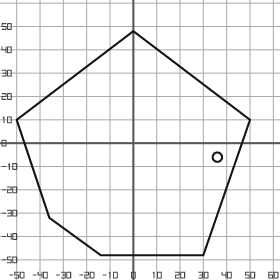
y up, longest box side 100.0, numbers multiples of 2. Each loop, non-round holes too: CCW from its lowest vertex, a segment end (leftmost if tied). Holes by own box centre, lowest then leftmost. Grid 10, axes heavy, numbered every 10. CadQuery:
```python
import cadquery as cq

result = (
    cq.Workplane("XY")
    .moveTo(-14.0, -48.0)
    .lineTo(30.0, -48.0)
    .lineTo(50.0, 10.0)
    .lineTo(0.0, 48.0)
    .lineTo(-50.0, 10.0)
    .lineTo(-36.0, -32.0)
    .close()
    .moveTo(36.0, -6.0)
    .circle(2.0)
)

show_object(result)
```